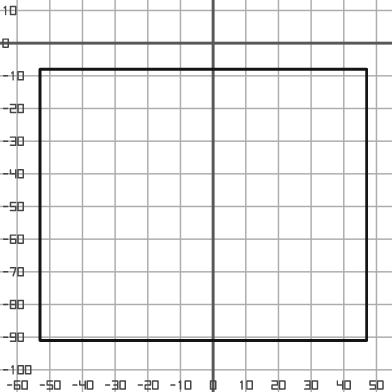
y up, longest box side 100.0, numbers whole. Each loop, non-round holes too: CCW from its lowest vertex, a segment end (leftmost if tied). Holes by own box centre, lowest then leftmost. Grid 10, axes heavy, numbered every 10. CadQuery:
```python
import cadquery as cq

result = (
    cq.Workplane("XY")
    .moveTo(-53.0, -91.0)
    .lineTo(47.0, -91.0)
    .lineTo(47.0, -8.0)
    .lineTo(-53.0, -8.0)
    .close()
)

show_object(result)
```